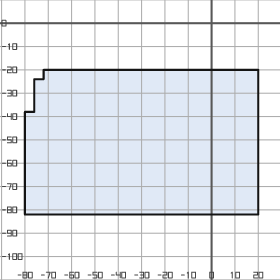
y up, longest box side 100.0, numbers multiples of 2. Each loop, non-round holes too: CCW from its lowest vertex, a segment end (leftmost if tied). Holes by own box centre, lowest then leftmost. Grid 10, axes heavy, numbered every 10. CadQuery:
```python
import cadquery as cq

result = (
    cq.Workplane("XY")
    .moveTo(-80.0, -82.0)
    .lineTo(20.0, -82.0)
    .lineTo(20.0, -20.0)
    .lineTo(-72.0, -20.0)
    .lineTo(-72.0, -24.0)
    .lineTo(-76.0, -24.0)
    .lineTo(-76.0, -38.0)
    .lineTo(-80.0, -38.0)
    .close()
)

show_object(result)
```